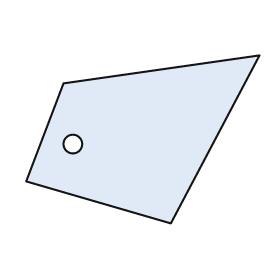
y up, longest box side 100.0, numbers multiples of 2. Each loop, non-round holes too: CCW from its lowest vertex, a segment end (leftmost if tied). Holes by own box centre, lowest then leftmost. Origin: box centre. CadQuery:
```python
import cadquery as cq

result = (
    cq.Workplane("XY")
    .moveTo(12.0, -36.0)
    .lineTo(50.0, 36.0)
    .lineTo(-34.0, 24.0)
    .lineTo(-50.0, -18.0)
    .close()
    .moveTo(-30.0, -2.0)
    .circle(4.0)
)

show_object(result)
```